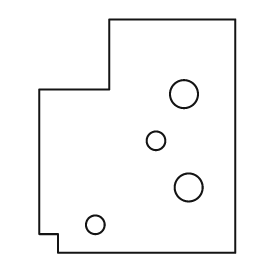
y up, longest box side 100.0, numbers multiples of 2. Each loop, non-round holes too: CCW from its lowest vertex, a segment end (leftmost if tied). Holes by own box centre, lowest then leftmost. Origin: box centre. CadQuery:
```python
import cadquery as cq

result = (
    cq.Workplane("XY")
    .moveTo(-34.0, -50.0)
    .lineTo(42.0, -50.0)
    .lineTo(42.0, 50.0)
    .lineTo(-12.0, 50.0)
    .lineTo(-12.0, 20.0)
    .lineTo(-42.0, 20.0)
    .lineTo(-42.0, -42.0)
    .lineTo(-34.0, -42.0)
    .close()
    .moveTo(-18.0, -38.0)
    .circle(4.0)
    .moveTo(22.0, -22.0)
    .circle(6.0)
    .moveTo(8.0, -2.0)
    .circle(4.0)
    .moveTo(20.0, 18.0)
    .circle(6.0)
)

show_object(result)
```